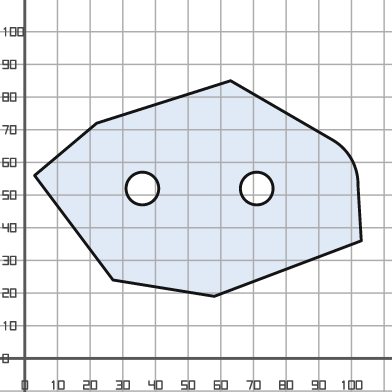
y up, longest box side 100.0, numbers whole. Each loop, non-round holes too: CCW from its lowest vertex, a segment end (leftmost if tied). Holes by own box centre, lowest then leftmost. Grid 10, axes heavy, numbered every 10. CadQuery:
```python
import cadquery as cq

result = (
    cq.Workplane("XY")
    .moveTo(58.0, 19.0)
    .lineTo(103.0, 36.0)
    .lineTo(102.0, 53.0)
    .threePointArc((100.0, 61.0), (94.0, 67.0))
    .lineTo(63.0, 85.0)
    .lineTo(22.0, 72.0)
    .lineTo(3.0, 56.0)
    .lineTo(27.0, 24.0)
    .close()
    .moveTo(36.0, 52.0)
    .circle(5.0)
    .moveTo(71.0, 52.0)
    .circle(5.0)
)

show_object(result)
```